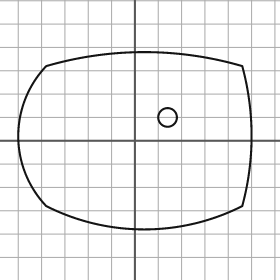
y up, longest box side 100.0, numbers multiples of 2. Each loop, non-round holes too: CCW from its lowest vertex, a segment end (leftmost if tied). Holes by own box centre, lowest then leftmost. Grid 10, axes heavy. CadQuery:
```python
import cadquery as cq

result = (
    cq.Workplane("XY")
    .moveTo(-38.0, -28.0)
    .threePointArc((4.0, -38.0), (46.0, -28.0))
    .threePointArc((50.0, 2.0), (46.0, 32.0))
    .threePointArc((4.0, 38.0), (-38.0, 32.0))
    .threePointArc((-50.0, 2.0), (-38.0, -28.0))
    .close()
    .moveTo(14.0, 10.0)
    .circle(4.0)
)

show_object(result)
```